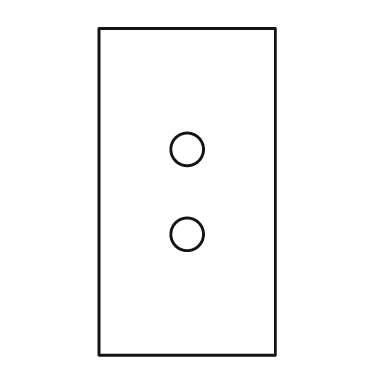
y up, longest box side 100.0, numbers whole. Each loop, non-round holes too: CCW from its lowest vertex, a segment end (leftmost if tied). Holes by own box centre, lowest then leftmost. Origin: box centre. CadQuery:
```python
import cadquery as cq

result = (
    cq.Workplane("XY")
    .moveTo(-27.0, -50.0)
    .lineTo(27.0, -50.0)
    .lineTo(27.0, 50.0)
    .lineTo(-27.0, 50.0)
    .close()
    .moveTo(0.0, -13.0)
    .circle(5.0)
    .moveTo(0.0, 13.0)
    .circle(5.0)
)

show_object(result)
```